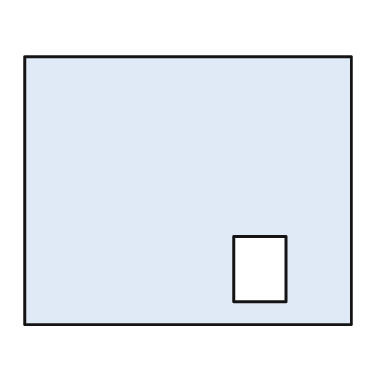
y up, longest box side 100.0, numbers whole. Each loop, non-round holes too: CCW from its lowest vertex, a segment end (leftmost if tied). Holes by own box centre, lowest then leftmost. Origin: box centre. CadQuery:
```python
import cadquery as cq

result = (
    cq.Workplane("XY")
    .moveTo(-50.0, -41.0)
    .lineTo(50.0, -41.0)
    .lineTo(50.0, 41.0)
    .lineTo(-50.0, 41.0)
    .close()
    .moveTo(14.0, -34.0)
    .lineTo(30.0, -34.0)
    .lineTo(30.0, -14.0)
    .lineTo(14.0, -14.0)
    .close()
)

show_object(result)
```